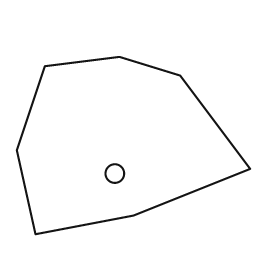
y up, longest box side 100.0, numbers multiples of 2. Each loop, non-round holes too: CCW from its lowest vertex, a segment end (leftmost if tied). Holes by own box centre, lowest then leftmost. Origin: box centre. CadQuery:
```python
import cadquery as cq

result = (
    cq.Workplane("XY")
    .moveTo(-42.0, -38.0)
    .lineTo(0.0, -30.0)
    .lineTo(50.0, -10.0)
    .lineTo(20.0, 30.0)
    .lineTo(-6.0, 38.0)
    .lineTo(-38.0, 34.0)
    .lineTo(-50.0, -2.0)
    .close()
    .moveTo(-8.0, -12.0)
    .circle(4.0)
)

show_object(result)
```